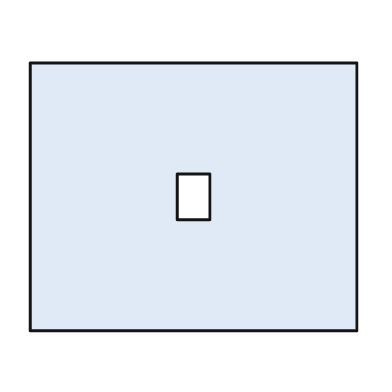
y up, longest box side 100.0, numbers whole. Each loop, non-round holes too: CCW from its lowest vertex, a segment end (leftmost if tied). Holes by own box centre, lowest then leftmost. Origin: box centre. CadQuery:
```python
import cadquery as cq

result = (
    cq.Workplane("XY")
    .moveTo(-50.0, -41.0)
    .lineTo(50.0, -41.0)
    .lineTo(50.0, 41.0)
    .lineTo(-50.0, 41.0)
    .close()
    .moveTo(-5.0, -7.0)
    .lineTo(5.0, -7.0)
    .lineTo(5.0, 7.0)
    .lineTo(-5.0, 7.0)
    .close()
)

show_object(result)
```